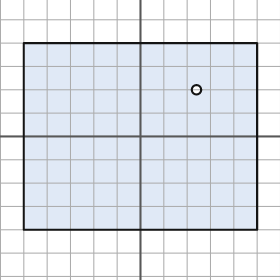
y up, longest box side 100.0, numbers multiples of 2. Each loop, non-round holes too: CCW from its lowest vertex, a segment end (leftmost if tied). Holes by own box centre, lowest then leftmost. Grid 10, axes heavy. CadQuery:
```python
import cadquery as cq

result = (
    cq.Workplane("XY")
    .moveTo(-50.0, -40.0)
    .lineTo(50.0, -40.0)
    .lineTo(50.0, 40.0)
    .lineTo(-50.0, 40.0)
    .close()
    .moveTo(24.0, 20.0)
    .circle(2.0)
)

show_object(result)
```